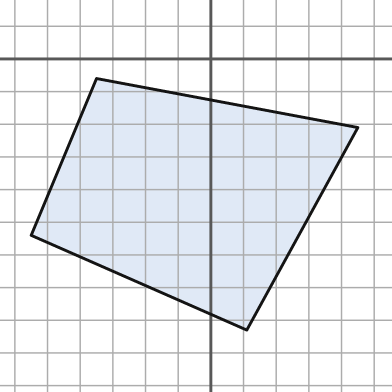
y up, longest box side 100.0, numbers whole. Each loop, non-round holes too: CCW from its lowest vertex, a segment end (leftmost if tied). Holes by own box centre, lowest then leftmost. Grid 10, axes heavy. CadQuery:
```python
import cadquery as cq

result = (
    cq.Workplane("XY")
    .moveTo(11.0, -83.0)
    .lineTo(45.0, -21.0)
    .lineTo(-35.0, -6.0)
    .lineTo(-55.0, -54.0)
    .close()
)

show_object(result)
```